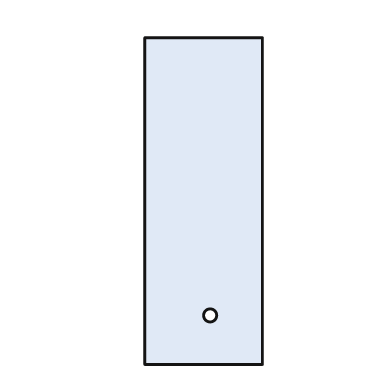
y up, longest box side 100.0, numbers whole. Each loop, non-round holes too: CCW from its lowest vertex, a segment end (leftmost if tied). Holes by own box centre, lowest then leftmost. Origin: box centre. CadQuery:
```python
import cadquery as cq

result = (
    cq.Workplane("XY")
    .moveTo(-18.0, -50.0)
    .lineTo(18.0, -50.0)
    .lineTo(18.0, 50.0)
    .lineTo(-18.0, 50.0)
    .close()
    .moveTo(2.0, -35.0)
    .circle(2.0)
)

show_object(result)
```